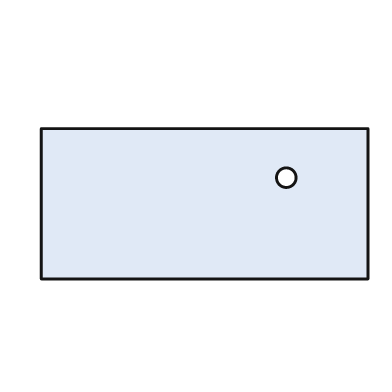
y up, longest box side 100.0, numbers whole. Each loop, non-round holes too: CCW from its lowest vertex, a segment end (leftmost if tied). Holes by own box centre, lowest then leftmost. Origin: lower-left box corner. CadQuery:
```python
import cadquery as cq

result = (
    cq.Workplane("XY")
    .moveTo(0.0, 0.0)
    .lineTo(100.0, 0.0)
    .lineTo(100.0, 46.0)
    .lineTo(0.0, 46.0)
    .close()
    .moveTo(75.0, 31.0)
    .circle(3.0)
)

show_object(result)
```